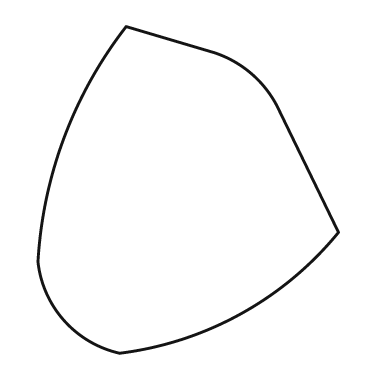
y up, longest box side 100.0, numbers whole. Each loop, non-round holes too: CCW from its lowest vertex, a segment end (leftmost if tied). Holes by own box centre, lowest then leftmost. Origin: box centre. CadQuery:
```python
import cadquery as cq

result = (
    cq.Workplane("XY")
    .moveTo(-21.0, -50.0)
    .threePointArc((16.0, -38.0), (46.0, -13.0))
    .lineTo(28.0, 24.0)
    .threePointArc((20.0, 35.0), (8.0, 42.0))
    .lineTo(-19.0, 50.0)
    .threePointArc((-38.0, 16.0), (-46.0, -22.0))
    .threePointArc((-38.0, -40.0), (-21.0, -50.0))
    .close()
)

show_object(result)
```